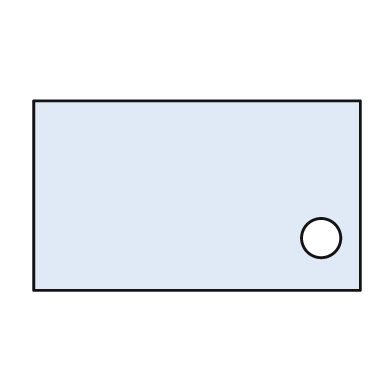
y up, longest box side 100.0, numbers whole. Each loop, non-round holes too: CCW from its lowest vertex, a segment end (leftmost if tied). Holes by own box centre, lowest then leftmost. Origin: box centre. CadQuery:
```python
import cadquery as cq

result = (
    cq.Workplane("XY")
    .moveTo(-50.0, -29.0)
    .lineTo(50.0, -29.0)
    .lineTo(50.0, 29.0)
    .lineTo(-50.0, 29.0)
    .close()
    .moveTo(38.0, -13.0)
    .circle(6.0)
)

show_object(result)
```